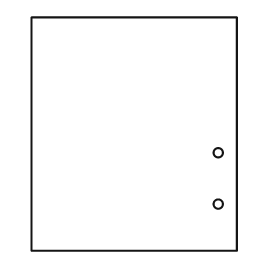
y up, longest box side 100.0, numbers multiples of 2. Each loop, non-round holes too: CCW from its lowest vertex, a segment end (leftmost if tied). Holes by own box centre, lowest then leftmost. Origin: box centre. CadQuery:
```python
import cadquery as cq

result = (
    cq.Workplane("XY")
    .moveTo(-44.0, -50.0)
    .lineTo(44.0, -50.0)
    .lineTo(44.0, 50.0)
    .lineTo(-44.0, 50.0)
    .close()
    .moveTo(36.0, -30.0)
    .circle(2.0)
    .moveTo(36.0, -8.0)
    .circle(2.0)
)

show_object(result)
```